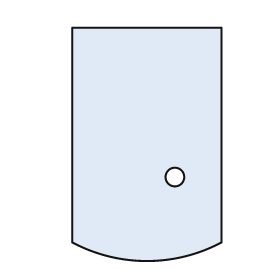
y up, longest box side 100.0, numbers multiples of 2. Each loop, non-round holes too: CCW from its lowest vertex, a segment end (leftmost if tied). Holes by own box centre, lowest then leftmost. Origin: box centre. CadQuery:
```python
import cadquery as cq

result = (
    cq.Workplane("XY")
    .moveTo(-32.0, -42.0)
    .threePointArc((0.0, -50.0), (32.0, -42.0))
    .lineTo(32.0, 50.0)
    .lineTo(-32.0, 50.0)
    .close()
    .moveTo(12.0, -14.0)
    .circle(4.0)
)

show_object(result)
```